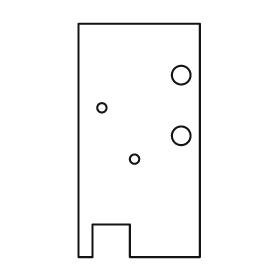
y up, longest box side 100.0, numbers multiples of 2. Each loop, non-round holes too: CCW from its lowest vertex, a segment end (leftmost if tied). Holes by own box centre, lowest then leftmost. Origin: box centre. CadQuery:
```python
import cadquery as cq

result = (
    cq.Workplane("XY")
    .moveTo(-26.0, -50.0)
    .lineTo(-20.0, -50.0)
    .lineTo(-20.0, -36.0)
    .lineTo(-4.0, -36.0)
    .lineTo(-4.0, -50.0)
    .lineTo(26.0, -50.0)
    .lineTo(26.0, 50.0)
    .lineTo(-26.0, 50.0)
    .close()
    .moveTo(-2.0, -8.0)
    .circle(2.0)
    .moveTo(18.0, 2.0)
    .circle(4.0)
    .moveTo(-16.0, 14.0)
    .circle(2.0)
    .moveTo(18.0, 28.0)
    .circle(4.0)
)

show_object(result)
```